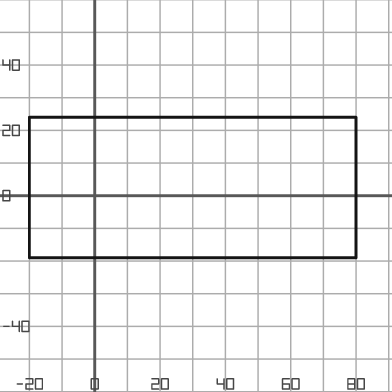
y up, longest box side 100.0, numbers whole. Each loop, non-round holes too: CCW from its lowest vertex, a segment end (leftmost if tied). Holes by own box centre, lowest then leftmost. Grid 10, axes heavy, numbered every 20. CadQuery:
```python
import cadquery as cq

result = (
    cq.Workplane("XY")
    .moveTo(-20.0, -19.0)
    .lineTo(80.0, -19.0)
    .lineTo(80.0, 24.0)
    .lineTo(-20.0, 24.0)
    .close()
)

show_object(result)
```